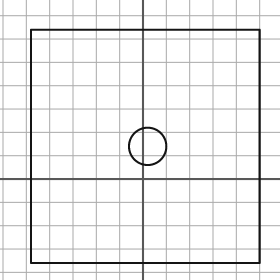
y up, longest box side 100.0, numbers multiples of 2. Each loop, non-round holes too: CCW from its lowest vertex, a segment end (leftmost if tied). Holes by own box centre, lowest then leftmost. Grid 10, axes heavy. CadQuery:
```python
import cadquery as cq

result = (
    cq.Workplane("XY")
    .moveTo(-48.0, -36.0)
    .lineTo(50.0, -36.0)
    .lineTo(50.0, 64.0)
    .lineTo(-48.0, 64.0)
    .close()
    .moveTo(2.0, 14.0)
    .circle(8.0)
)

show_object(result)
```